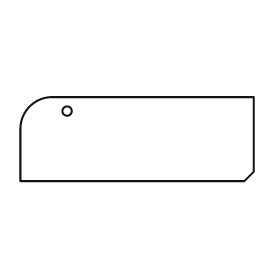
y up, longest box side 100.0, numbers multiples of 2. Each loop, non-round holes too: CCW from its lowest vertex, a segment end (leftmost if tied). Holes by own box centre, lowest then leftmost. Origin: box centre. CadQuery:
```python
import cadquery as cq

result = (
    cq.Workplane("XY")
    .moveTo(-50.0, -18.0)
    .lineTo(46.0, -18.0)
    .lineTo(50.0, -14.0)
    .lineTo(50.0, 18.0)
    .lineTo(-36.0, 18.0)
    .threePointArc((-46.0, 14.0), (-50.0, 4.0))
    .close()
    .moveTo(-30.0, 12.0)
    .circle(2.0)
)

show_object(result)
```